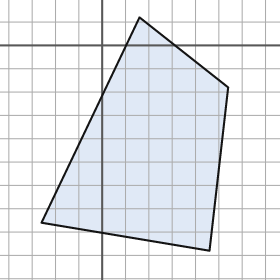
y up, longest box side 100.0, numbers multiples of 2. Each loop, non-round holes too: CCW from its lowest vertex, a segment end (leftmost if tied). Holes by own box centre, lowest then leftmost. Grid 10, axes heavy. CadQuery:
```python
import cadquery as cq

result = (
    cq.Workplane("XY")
    .moveTo(46.0, -88.0)
    .lineTo(54.0, -18.0)
    .lineTo(16.0, 12.0)
    .lineTo(-26.0, -76.0)
    .close()
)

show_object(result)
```